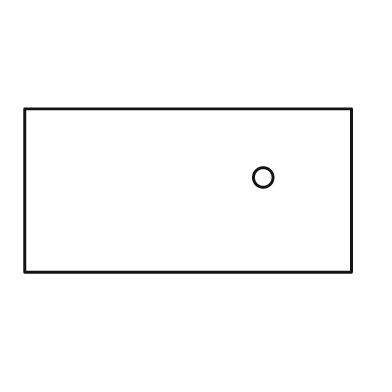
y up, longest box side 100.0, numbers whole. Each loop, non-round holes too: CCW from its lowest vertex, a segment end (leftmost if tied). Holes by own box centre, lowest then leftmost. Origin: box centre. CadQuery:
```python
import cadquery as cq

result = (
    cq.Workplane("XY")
    .moveTo(-50.0, -25.0)
    .lineTo(50.0, -25.0)
    .lineTo(50.0, 25.0)
    .lineTo(-50.0, 25.0)
    .close()
    .moveTo(23.0, 4.0)
    .circle(3.0)
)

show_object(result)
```